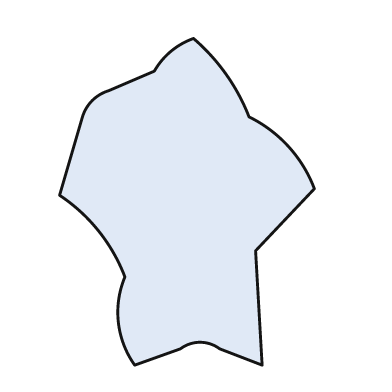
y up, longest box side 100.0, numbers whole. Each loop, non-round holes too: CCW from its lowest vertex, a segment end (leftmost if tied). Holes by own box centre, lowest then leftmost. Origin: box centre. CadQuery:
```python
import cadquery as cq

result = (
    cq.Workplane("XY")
    .moveTo(-16.0, -50.0)
    .lineTo(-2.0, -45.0)
    .threePointArc((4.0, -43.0), (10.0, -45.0))
    .lineTo(23.0, -50.0)
    .lineTo(21.0, -15.0)
    .lineTo(39.0, 4.0)
    .threePointArc((31.0, 17.0), (19.0, 26.0))
    .threePointArc((12.0, 39.0), (2.0, 50.0))
    .threePointArc((-5.0, 46.0), (-10.0, 40.0))
    .lineTo(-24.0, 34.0)
    .threePointArc((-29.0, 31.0), (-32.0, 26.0))
    .lineTo(-39.0, 2.0)
    .threePointArc((-27.0, -9.0), (-19.0, -23.0))
    .threePointArc((-21.0, -37.0), (-16.0, -50.0))
    .close()
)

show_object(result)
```